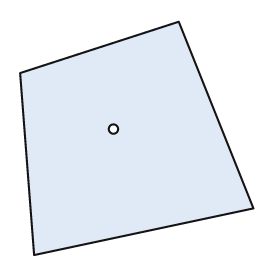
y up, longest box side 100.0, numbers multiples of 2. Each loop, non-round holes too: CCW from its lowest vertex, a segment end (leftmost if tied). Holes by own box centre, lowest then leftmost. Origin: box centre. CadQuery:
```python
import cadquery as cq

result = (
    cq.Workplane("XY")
    .moveTo(-44.0, -50.0)
    .lineTo(50.0, -30.0)
    .lineTo(18.0, 50.0)
    .lineTo(-50.0, 28.0)
    .close()
    .moveTo(-10.0, 4.0)
    .circle(2.0)
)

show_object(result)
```